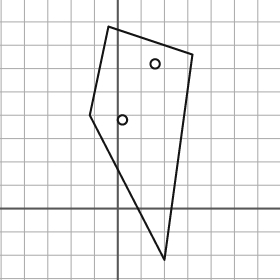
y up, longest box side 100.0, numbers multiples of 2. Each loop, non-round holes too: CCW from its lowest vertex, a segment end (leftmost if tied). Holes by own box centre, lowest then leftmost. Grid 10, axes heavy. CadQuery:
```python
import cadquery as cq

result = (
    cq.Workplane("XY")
    .moveTo(20.0, -22.0)
    .lineTo(32.0, 66.0)
    .lineTo(-4.0, 78.0)
    .lineTo(-12.0, 40.0)
    .close()
    .moveTo(2.0, 38.0)
    .circle(2.0)
    .moveTo(16.0, 62.0)
    .circle(2.0)
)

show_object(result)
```